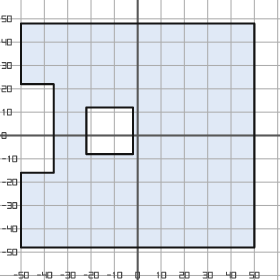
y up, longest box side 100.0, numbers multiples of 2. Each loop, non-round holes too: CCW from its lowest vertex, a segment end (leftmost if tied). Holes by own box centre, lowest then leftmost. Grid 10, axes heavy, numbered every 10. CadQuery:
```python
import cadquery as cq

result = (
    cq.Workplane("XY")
    .moveTo(-50.0, -48.0)
    .lineTo(50.0, -48.0)
    .lineTo(50.0, 48.0)
    .lineTo(-50.0, 48.0)
    .lineTo(-50.0, 22.0)
    .lineTo(-36.0, 22.0)
    .lineTo(-36.0, -16.0)
    .lineTo(-50.0, -16.0)
    .close()
    .moveTo(-22.0, -8.0)
    .lineTo(-2.0, -8.0)
    .lineTo(-2.0, 12.0)
    .lineTo(-22.0, 12.0)
    .close()
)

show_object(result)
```